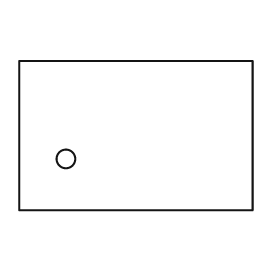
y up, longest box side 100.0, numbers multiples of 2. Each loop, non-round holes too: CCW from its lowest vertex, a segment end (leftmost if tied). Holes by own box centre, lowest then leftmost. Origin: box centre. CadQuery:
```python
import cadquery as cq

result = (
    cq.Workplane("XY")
    .moveTo(-50.0, -32.0)
    .lineTo(50.0, -32.0)
    .lineTo(50.0, 32.0)
    .lineTo(-50.0, 32.0)
    .close()
    .moveTo(-30.0, -10.0)
    .circle(4.0)
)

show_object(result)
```